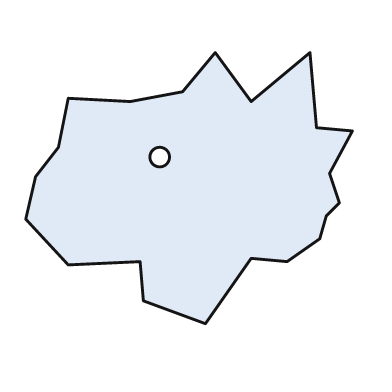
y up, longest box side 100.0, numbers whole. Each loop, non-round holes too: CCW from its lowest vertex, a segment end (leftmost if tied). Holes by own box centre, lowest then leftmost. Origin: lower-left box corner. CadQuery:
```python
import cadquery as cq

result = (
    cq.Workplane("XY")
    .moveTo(55.0, 0.0)
    .lineTo(69.0, 20.0)
    .lineTo(80.0, 19.0)
    .lineTo(90.0, 26.0)
    .lineTo(92.0, 33.0)
    .lineTo(96.0, 37.0)
    .lineTo(93.0, 46.0)
    .lineTo(100.0, 59.0)
    .lineTo(89.0, 60.0)
    .lineTo(87.0, 83.0)
    .lineTo(69.0, 68.0)
    .lineTo(58.0, 83.0)
    .lineTo(48.0, 71.0)
    .lineTo(32.0, 68.0)
    .lineTo(13.0, 69.0)
    .lineTo(10.0, 54.0)
    .lineTo(3.0, 45.0)
    .lineTo(0.0, 32.0)
    .lineTo(13.0, 18.0)
    .lineTo(35.0, 19.0)
    .lineTo(36.0, 7.0)
    .close()
    .moveTo(41.0, 51.0)
    .circle(3.0)
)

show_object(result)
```